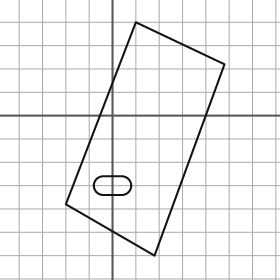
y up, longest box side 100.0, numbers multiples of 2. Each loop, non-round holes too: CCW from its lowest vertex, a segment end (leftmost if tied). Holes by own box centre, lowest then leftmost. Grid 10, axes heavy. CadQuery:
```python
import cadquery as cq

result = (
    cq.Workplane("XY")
    .moveTo(18.0, -60.0)
    .lineTo(48.0, 22.0)
    .lineTo(10.0, 40.0)
    .lineTo(-20.0, -38.0)
    .close()
    .moveTo(-4.0, -34.0)
    .lineTo(4.0, -34.0)
    .threePointArc((8.0, -30.0), (4.0, -26.0))
    .lineTo(-4.0, -26.0)
    .threePointArc((-8.0, -30.0), (-4.0, -34.0))
    .close()
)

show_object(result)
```